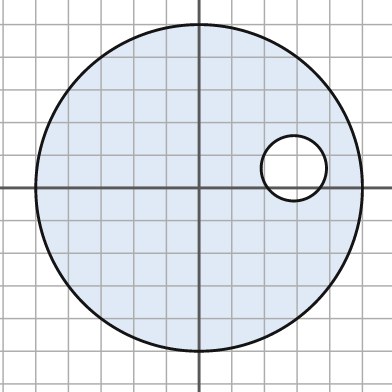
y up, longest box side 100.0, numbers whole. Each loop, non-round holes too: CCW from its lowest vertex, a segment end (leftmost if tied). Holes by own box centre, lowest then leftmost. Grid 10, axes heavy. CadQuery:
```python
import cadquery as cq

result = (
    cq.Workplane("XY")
    .moveTo(0.0, 0.0)
    .circle(50.0)
    .moveTo(29.0, 6.0)
    .circle(10.0)
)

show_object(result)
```